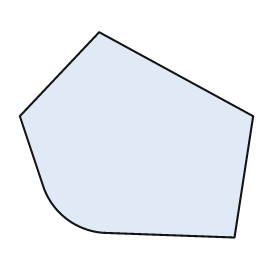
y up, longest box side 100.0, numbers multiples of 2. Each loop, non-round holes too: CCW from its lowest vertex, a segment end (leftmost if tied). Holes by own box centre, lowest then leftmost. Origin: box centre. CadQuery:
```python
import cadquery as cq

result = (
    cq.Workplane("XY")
    .moveTo(42.0, -44.0)
    .lineTo(50.0, 8.0)
    .lineTo(-16.0, 44.0)
    .lineTo(-50.0, 8.0)
    .lineTo(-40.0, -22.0)
    .threePointArc((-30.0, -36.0), (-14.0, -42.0))
    .close()
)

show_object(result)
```